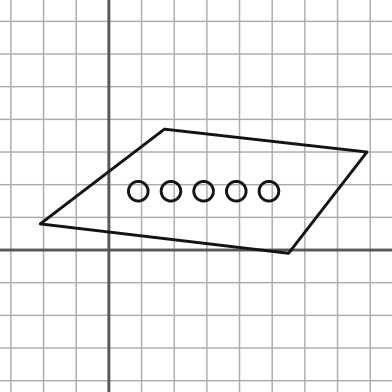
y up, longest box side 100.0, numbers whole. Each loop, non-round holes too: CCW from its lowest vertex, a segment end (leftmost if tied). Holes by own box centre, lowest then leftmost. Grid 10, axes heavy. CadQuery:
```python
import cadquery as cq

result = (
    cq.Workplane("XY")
    .moveTo(55.0, -1.0)
    .lineTo(79.0, 30.0)
    .lineTo(17.0, 37.0)
    .lineTo(-21.0, 8.0)
    .close()
    .moveTo(9.0, 18.0)
    .circle(3.0)
    .moveTo(19.0, 18.0)
    .circle(3.0)
    .moveTo(29.0, 18.0)
    .circle(3.0)
    .moveTo(39.0, 18.0)
    .circle(3.0)
    .moveTo(49.0, 18.0)
    .circle(3.0)
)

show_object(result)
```